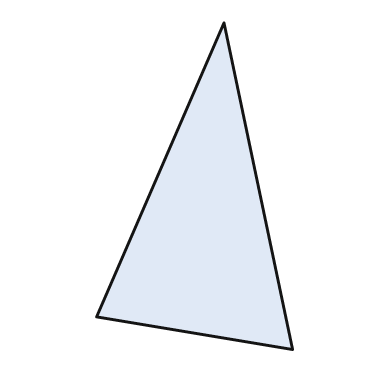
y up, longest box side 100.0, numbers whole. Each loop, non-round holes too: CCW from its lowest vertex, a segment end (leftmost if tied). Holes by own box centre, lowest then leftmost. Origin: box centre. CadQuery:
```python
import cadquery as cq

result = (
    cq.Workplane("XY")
    .moveTo(30.0, -50.0)
    .lineTo(9.0, 50.0)
    .lineTo(-30.0, -40.0)
    .close()
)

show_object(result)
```